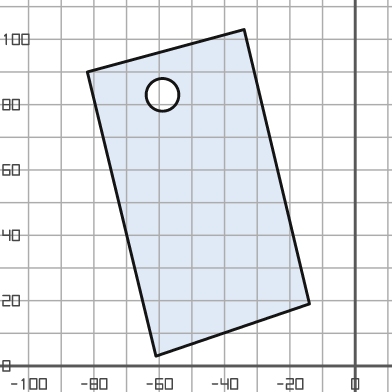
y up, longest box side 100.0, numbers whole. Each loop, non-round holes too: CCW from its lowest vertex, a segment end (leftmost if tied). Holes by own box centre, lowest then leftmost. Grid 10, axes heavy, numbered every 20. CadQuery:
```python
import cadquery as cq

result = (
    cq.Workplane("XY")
    .moveTo(-61.0, 3.0)
    .lineTo(-14.0, 19.0)
    .lineTo(-34.0, 103.0)
    .lineTo(-82.0, 90.0)
    .close()
    .moveTo(-59.0, 83.0)
    .circle(5.0)
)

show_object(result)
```